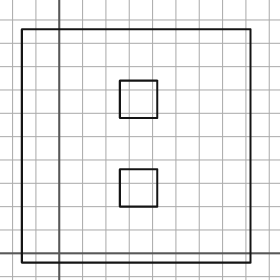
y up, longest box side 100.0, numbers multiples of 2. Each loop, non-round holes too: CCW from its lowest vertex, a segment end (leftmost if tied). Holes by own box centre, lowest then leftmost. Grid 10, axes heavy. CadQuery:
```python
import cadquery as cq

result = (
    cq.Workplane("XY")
    .moveTo(-16.0, -4.0)
    .lineTo(82.0, -4.0)
    .lineTo(82.0, 96.0)
    .lineTo(-16.0, 96.0)
    .close()
    .moveTo(26.0, 20.0)
    .lineTo(42.0, 20.0)
    .lineTo(42.0, 36.0)
    .lineTo(26.0, 36.0)
    .close()
    .moveTo(26.0, 58.0)
    .lineTo(42.0, 58.0)
    .lineTo(42.0, 74.0)
    .lineTo(26.0, 74.0)
    .close()
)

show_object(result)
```